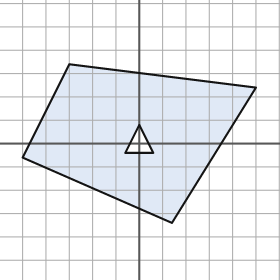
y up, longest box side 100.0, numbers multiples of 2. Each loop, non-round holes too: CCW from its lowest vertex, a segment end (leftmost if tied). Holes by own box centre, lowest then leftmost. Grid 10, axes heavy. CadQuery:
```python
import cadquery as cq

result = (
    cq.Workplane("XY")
    .moveTo(14.0, -34.0)
    .lineTo(50.0, 24.0)
    .lineTo(-30.0, 34.0)
    .lineTo(-50.0, -6.0)
    .close()
    .moveTo(-6.0, -4.0)
    .lineTo(6.0, -4.0)
    .lineTo(0.0, 8.0)
    .close()
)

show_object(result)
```